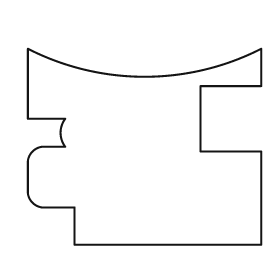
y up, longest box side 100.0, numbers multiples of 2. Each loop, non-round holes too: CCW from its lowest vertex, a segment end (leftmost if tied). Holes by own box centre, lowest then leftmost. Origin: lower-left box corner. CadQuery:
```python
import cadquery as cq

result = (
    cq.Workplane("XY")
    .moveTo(20.0, 0.0)
    .lineTo(100.0, 0.0)
    .lineTo(100.0, 40.0)
    .lineTo(74.0, 40.0)
    .lineTo(74.0, 68.0)
    .lineTo(100.0, 68.0)
    .lineTo(100.0, 84.0)
    .threePointArc((50.0, 72.0), (0.0, 84.0))
    .lineTo(0.0, 54.0)
    .lineTo(16.0, 54.0)
    .threePointArc((14.0, 48.0), (16.0, 42.0))
    .lineTo(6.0, 42.0)
    .threePointArc((2.0, 40.0), (0.0, 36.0))
    .lineTo(0.0, 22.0)
    .threePointArc((2.0, 18.0), (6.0, 16.0))
    .lineTo(20.0, 16.0)
    .close()
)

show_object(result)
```